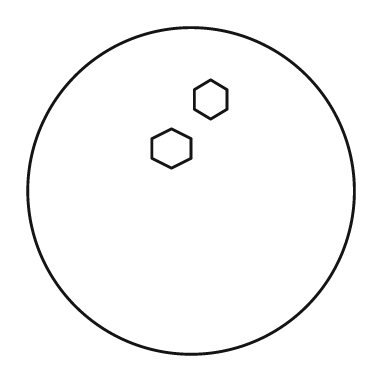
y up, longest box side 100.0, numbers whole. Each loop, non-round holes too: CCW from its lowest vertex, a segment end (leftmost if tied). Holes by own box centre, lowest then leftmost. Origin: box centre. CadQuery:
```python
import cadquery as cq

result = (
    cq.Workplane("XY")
    .moveTo(0.0, 0.0)
    .circle(50.0)
    .moveTo(-6.0, 7.0)
    .lineTo(0.0, 10.0)
    .lineTo(0.0, 16.0)
    .lineTo(-6.0, 19.0)
    .lineTo(-12.0, 16.0)
    .lineTo(-12.0, 10.0)
    .close()
    .moveTo(6.0, 22.0)
    .lineTo(11.0, 25.0)
    .lineTo(11.0, 31.0)
    .lineTo(6.0, 34.0)
    .lineTo(1.0, 31.0)
    .lineTo(1.0, 25.0)
    .close()
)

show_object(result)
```